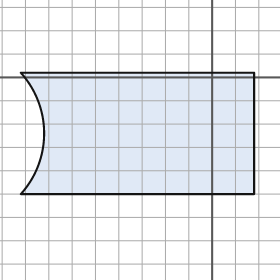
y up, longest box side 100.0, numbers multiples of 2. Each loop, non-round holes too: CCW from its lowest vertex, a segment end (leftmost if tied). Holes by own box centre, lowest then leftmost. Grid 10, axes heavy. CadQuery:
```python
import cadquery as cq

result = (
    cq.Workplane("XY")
    .moveTo(-82.0, -50.0)
    .lineTo(18.0, -50.0)
    .lineTo(18.0, 2.0)
    .lineTo(-82.0, 2.0)
    .threePointArc((-72.0, -24.0), (-82.0, -50.0))
    .close()
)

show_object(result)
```